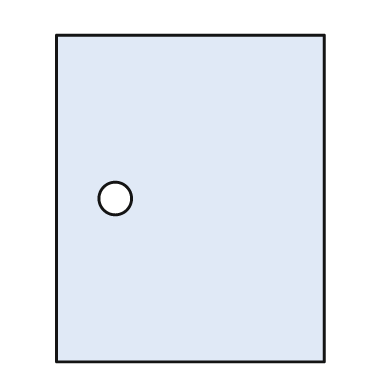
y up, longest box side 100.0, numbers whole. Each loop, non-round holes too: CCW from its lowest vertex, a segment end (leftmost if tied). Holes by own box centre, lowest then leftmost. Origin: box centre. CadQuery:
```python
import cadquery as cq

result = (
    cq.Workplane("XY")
    .moveTo(-41.0, -50.0)
    .lineTo(41.0, -50.0)
    .lineTo(41.0, 50.0)
    .lineTo(-41.0, 50.0)
    .close()
    .moveTo(-23.0, 0.0)
    .circle(5.0)
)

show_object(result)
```